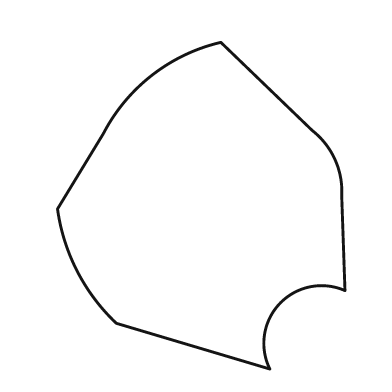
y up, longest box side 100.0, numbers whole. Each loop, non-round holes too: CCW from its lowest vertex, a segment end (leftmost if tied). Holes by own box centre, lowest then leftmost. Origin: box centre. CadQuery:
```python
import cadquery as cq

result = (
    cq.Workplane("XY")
    .moveTo(21.0, -50.0)
    .threePointArc((24.0, -30.0), (44.0, -26.0))
    .lineTo(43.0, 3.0)
    .threePointArc((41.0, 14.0), (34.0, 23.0))
    .lineTo(6.0, 50.0)
    .threePointArc((-15.0, 40.0), (-30.0, 22.0))
    .lineTo(-44.0, -1.0)
    .threePointArc((-38.0, -20.0), (-26.0, -36.0))
    .close()
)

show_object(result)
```